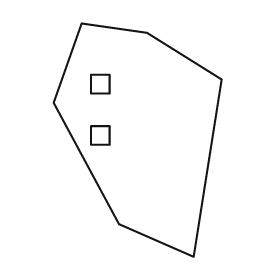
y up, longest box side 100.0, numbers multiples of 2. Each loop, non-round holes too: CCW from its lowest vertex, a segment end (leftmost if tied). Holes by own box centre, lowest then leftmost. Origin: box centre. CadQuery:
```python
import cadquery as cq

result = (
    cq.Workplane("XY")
    .moveTo(24.0, -50.0)
    .lineTo(36.0, 26.0)
    .lineTo(4.0, 46.0)
    .lineTo(-24.0, 50.0)
    .lineTo(-36.0, 16.0)
    .lineTo(-8.0, -36.0)
    .close()
    .moveTo(-20.0, -2.0)
    .lineTo(-12.0, -2.0)
    .lineTo(-12.0, 6.0)
    .lineTo(-20.0, 6.0)
    .close()
    .moveTo(-20.0, 20.0)
    .lineTo(-12.0, 20.0)
    .lineTo(-12.0, 28.0)
    .lineTo(-20.0, 28.0)
    .close()
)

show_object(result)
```